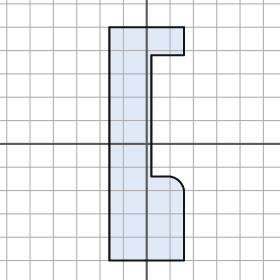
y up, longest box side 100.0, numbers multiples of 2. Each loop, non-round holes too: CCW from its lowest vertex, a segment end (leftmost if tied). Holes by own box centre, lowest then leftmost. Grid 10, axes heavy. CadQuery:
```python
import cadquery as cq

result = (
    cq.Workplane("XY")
    .moveTo(-16.0, -50.0)
    .lineTo(16.0, -50.0)
    .lineTo(16.0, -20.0)
    .threePointArc((14.0, -16.0), (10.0, -14.0))
    .lineTo(2.0, -14.0)
    .lineTo(2.0, 38.0)
    .lineTo(16.0, 38.0)
    .lineTo(16.0, 50.0)
    .lineTo(-16.0, 50.0)
    .close()
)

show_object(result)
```